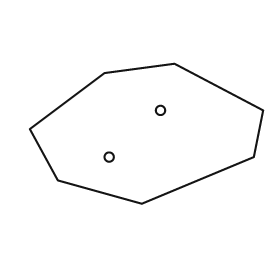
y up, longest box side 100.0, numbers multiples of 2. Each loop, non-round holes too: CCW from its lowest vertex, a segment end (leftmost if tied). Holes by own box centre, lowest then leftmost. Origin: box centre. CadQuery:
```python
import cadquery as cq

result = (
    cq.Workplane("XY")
    .moveTo(-2.0, -30.0)
    .lineTo(46.0, -10.0)
    .lineTo(50.0, 10.0)
    .lineTo(12.0, 30.0)
    .lineTo(-18.0, 26.0)
    .lineTo(-50.0, 2.0)
    .lineTo(-38.0, -20.0)
    .close()
    .moveTo(-16.0, -10.0)
    .circle(2.0)
    .moveTo(6.0, 10.0)
    .circle(2.0)
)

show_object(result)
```